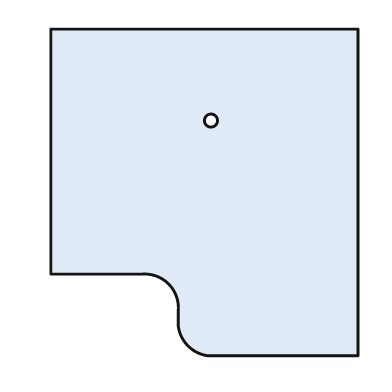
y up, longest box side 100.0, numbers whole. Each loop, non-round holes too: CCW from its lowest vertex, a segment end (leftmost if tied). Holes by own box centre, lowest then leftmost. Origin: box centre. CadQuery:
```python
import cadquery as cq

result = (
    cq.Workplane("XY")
    .moveTo(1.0, -50.0)
    .lineTo(47.0, -50.0)
    .lineTo(47.0, 50.0)
    .lineTo(-47.0, 50.0)
    .lineTo(-47.0, -25.0)
    .lineTo(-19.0, -25.0)
    .threePointArc((-11.0, -28.0), (-8.0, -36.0))
    .lineTo(-8.0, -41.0)
    .threePointArc((-5.0, -47.0), (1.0, -50.0))
    .close()
    .moveTo(2.0, 22.0)
    .circle(2.0)
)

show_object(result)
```